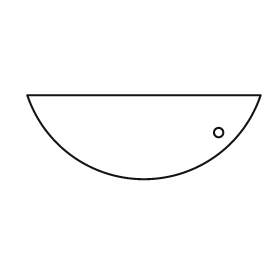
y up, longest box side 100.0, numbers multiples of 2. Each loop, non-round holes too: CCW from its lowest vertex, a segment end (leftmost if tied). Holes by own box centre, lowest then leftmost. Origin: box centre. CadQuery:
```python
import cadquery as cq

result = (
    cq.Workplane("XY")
    .moveTo(-50.0, 18.0)
    .threePointArc((0.0, -18.0), (50.0, 18.0))
    .close()
    .moveTo(32.0, 2.0)
    .circle(2.0)
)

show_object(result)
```